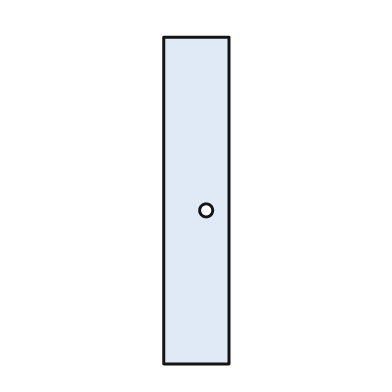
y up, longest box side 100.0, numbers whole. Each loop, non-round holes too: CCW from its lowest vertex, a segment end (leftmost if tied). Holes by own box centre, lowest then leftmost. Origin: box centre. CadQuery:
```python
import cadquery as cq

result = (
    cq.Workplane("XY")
    .moveTo(-10.0, -50.0)
    .lineTo(10.0, -50.0)
    .lineTo(10.0, 50.0)
    .lineTo(-10.0, 50.0)
    .close()
    .moveTo(3.0, -3.0)
    .circle(2.0)
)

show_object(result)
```